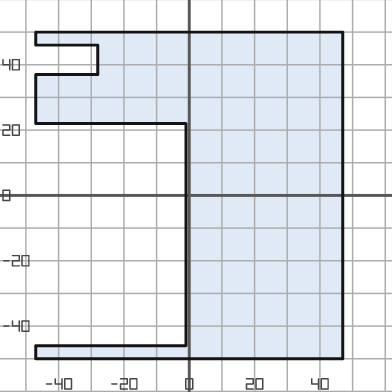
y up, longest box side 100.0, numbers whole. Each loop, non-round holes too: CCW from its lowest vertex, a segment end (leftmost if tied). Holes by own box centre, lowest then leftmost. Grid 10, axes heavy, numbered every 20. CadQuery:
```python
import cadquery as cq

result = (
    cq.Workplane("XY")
    .moveTo(-47.0, -50.0)
    .lineTo(47.0, -50.0)
    .lineTo(47.0, 50.0)
    .lineTo(-47.0, 50.0)
    .lineTo(-47.0, 46.0)
    .lineTo(-28.0, 46.0)
    .lineTo(-28.0, 37.0)
    .lineTo(-47.0, 37.0)
    .lineTo(-47.0, 22.0)
    .lineTo(-1.0, 22.0)
    .lineTo(-1.0, -46.0)
    .lineTo(-47.0, -46.0)
    .close()
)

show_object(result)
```